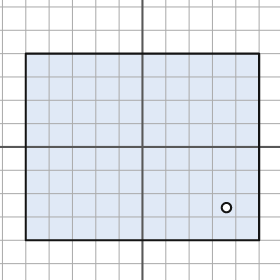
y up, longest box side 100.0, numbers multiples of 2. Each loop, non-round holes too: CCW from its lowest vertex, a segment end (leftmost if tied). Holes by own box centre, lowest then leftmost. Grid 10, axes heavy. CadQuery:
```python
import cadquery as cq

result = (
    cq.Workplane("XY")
    .moveTo(-50.0, -40.0)
    .lineTo(50.0, -40.0)
    .lineTo(50.0, 40.0)
    .lineTo(-50.0, 40.0)
    .close()
    .moveTo(36.0, -26.0)
    .circle(2.0)
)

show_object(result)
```